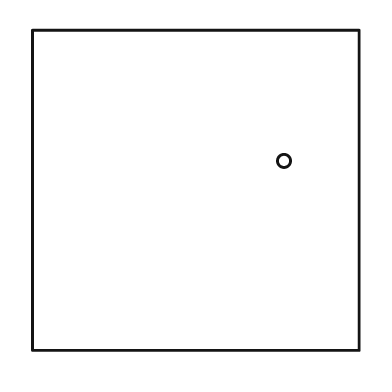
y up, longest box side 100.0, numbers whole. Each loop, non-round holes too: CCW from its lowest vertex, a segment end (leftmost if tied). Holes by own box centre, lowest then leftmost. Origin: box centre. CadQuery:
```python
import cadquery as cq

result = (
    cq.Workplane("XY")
    .moveTo(-50.0, -49.0)
    .lineTo(50.0, -49.0)
    .lineTo(50.0, 49.0)
    .lineTo(-50.0, 49.0)
    .close()
    .moveTo(27.0, 9.0)
    .circle(2.0)
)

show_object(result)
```